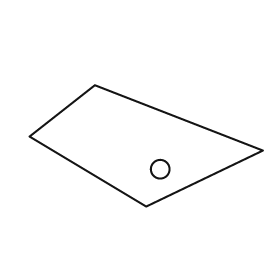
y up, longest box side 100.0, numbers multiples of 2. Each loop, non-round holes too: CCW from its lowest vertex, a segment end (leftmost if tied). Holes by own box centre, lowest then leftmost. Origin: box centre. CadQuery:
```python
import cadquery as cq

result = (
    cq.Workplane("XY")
    .moveTo(0.0, -26.0)
    .lineTo(50.0, -2.0)
    .lineTo(-22.0, 26.0)
    .lineTo(-50.0, 4.0)
    .close()
    .moveTo(6.0, -10.0)
    .circle(4.0)
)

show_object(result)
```